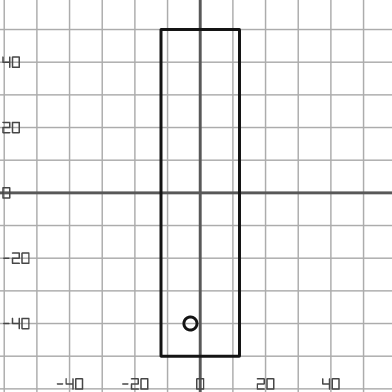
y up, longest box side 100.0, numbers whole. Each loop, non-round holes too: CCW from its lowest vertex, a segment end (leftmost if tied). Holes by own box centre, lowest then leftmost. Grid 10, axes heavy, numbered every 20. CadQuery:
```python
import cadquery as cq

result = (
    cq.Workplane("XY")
    .moveTo(-12.0, -50.0)
    .lineTo(12.0, -50.0)
    .lineTo(12.0, 50.0)
    .lineTo(-12.0, 50.0)
    .close()
    .moveTo(-3.0, -40.0)
    .circle(2.0)
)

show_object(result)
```